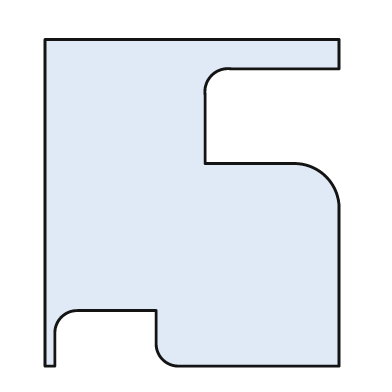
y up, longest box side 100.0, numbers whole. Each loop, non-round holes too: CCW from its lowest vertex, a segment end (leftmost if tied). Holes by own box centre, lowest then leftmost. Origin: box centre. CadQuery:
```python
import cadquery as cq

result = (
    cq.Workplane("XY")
    .moveTo(-45.0, -50.0)
    .lineTo(-42.0, -50.0)
    .lineTo(-42.0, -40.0)
    .threePointArc((-40.0, -35.0), (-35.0, -33.0))
    .lineTo(-11.0, -33.0)
    .lineTo(-11.0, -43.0)
    .threePointArc((-9.0, -48.0), (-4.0, -50.0))
    .lineTo(45.0, -50.0)
    .lineTo(45.0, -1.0)
    .threePointArc((41.0, 8.0), (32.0, 12.0))
    .lineTo(4.0, 12.0)
    .lineTo(4.0, 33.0)
    .threePointArc((6.0, 39.0), (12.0, 41.0))
    .lineTo(45.0, 41.0)
    .lineTo(45.0, 50.0)
    .lineTo(-45.0, 50.0)
    .close()
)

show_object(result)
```